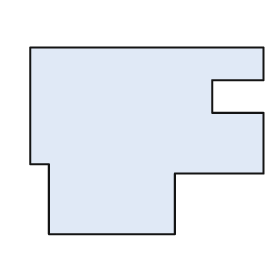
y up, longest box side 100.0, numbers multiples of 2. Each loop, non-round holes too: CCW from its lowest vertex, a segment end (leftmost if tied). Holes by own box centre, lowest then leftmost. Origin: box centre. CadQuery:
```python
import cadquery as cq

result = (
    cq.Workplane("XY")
    .moveTo(-42.0, -40.0)
    .lineTo(12.0, -40.0)
    .lineTo(12.0, -14.0)
    .lineTo(50.0, -14.0)
    .lineTo(50.0, 12.0)
    .lineTo(28.0, 12.0)
    .lineTo(28.0, 26.0)
    .lineTo(50.0, 26.0)
    .lineTo(50.0, 40.0)
    .lineTo(-50.0, 40.0)
    .lineTo(-50.0, -10.0)
    .lineTo(-42.0, -10.0)
    .close()
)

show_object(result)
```